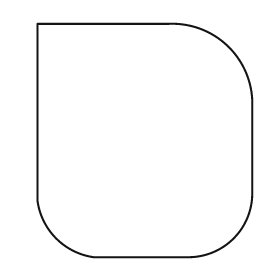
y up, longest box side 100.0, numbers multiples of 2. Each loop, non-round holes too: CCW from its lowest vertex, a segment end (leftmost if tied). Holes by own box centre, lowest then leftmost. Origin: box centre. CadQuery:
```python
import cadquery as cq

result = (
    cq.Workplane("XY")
    .moveTo(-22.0, -50.0)
    .lineTo(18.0, -50.0)
    .threePointArc((38.0, -42.0), (46.0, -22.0))
    .lineTo(46.0, 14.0)
    .threePointArc((36.0, 40.0), (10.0, 50.0))
    .lineTo(-46.0, 50.0)
    .lineTo(-46.0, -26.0)
    .threePointArc((-38.0, -42.0), (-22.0, -50.0))
    .close()
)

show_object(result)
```